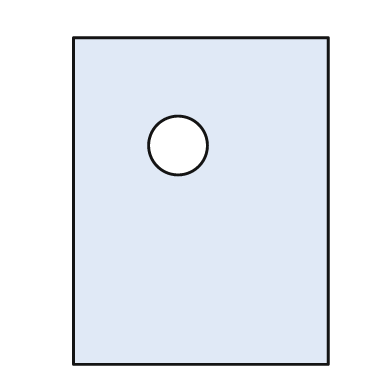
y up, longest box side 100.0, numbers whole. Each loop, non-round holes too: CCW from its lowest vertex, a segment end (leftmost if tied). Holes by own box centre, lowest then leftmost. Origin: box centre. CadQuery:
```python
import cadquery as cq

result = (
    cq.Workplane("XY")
    .moveTo(-39.0, -50.0)
    .lineTo(39.0, -50.0)
    .lineTo(39.0, 50.0)
    .lineTo(-39.0, 50.0)
    .close()
    .moveTo(-7.0, 17.0)
    .circle(9.0)
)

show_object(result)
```